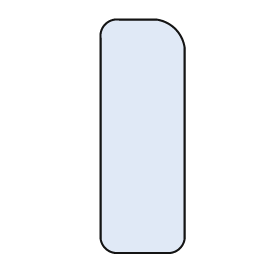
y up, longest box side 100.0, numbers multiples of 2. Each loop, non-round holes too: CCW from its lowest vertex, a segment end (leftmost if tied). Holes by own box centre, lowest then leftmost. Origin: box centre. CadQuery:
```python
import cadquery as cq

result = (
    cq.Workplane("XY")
    .moveTo(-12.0, -50.0)
    .lineTo(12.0, -50.0)
    .threePointArc((16.0, -48.0), (18.0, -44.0))
    .lineTo(18.0, 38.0)
    .threePointArc((14.0, 46.0), (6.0, 50.0))
    .lineTo(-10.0, 50.0)
    .threePointArc((-16.0, 48.0), (-18.0, 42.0))
    .lineTo(-18.0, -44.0)
    .threePointArc((-16.0, -48.0), (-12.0, -50.0))
    .close()
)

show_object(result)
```